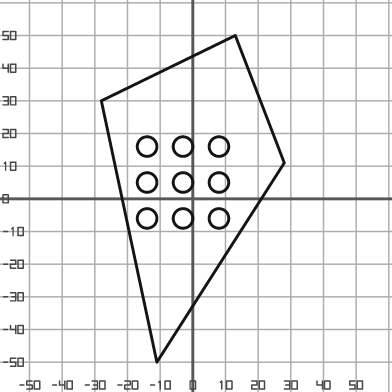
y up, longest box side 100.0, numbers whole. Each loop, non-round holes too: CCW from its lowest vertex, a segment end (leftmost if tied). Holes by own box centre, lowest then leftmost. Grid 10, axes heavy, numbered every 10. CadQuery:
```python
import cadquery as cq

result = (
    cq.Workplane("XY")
    .moveTo(-11.0, -50.0)
    .lineTo(28.0, 11.0)
    .lineTo(13.0, 50.0)
    .lineTo(-28.0, 30.0)
    .close()
    .moveTo(-14.0, -6.0)
    .circle(3.0)
    .moveTo(-3.0, -6.0)
    .circle(3.0)
    .moveTo(8.0, -6.0)
    .circle(3.0)
    .moveTo(-14.0, 5.0)
    .circle(3.0)
    .moveTo(-3.0, 5.0)
    .circle(3.0)
    .moveTo(8.0, 5.0)
    .circle(3.0)
    .moveTo(-14.0, 16.0)
    .circle(3.0)
    .moveTo(-3.0, 16.0)
    .circle(3.0)
    .moveTo(8.0, 16.0)
    .circle(3.0)
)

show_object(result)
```